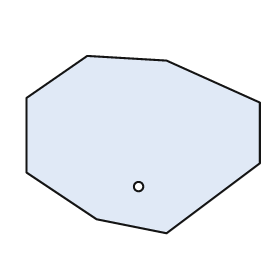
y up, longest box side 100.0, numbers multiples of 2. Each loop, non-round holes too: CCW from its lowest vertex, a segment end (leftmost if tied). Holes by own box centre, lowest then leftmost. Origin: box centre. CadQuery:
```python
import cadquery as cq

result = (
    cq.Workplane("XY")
    .moveTo(10.0, -38.0)
    .lineTo(50.0, -8.0)
    .lineTo(50.0, 18.0)
    .lineTo(10.0, 36.0)
    .lineTo(-24.0, 38.0)
    .lineTo(-50.0, 20.0)
    .lineTo(-50.0, -12.0)
    .lineTo(-20.0, -32.0)
    .close()
    .moveTo(-2.0, -18.0)
    .circle(2.0)
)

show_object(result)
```